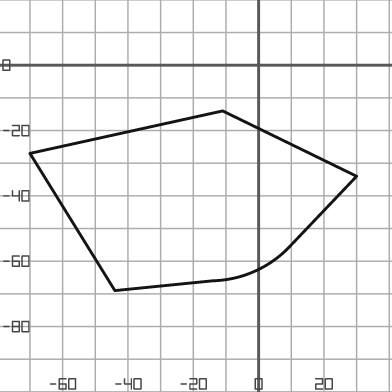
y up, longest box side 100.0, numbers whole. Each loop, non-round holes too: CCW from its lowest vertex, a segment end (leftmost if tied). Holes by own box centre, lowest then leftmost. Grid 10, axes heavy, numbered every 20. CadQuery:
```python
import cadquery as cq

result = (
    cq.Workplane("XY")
    .moveTo(-44.0, -69.0)
    .lineTo(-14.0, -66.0)
    .threePointArc((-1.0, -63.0), (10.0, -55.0))
    .lineTo(30.0, -34.0)
    .lineTo(-11.0, -14.0)
    .lineTo(-70.0, -27.0)
    .close()
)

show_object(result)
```